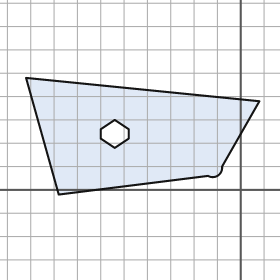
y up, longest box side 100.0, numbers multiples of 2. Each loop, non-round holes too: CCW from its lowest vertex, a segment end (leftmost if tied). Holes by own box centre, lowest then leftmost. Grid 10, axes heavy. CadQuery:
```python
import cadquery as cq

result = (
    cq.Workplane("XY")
    .moveTo(-78.0, -2.0)
    .lineTo(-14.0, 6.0)
    .threePointArc((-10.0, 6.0), (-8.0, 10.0))
    .lineTo(8.0, 38.0)
    .lineTo(-92.0, 48.0)
    .close()
    .moveTo(-54.0, 18.0)
    .lineTo(-48.0, 22.0)
    .lineTo(-48.0, 26.0)
    .lineTo(-54.0, 30.0)
    .lineTo(-60.0, 26.0)
    .lineTo(-60.0, 22.0)
    .close()
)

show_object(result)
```